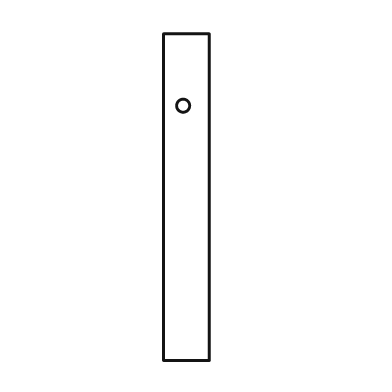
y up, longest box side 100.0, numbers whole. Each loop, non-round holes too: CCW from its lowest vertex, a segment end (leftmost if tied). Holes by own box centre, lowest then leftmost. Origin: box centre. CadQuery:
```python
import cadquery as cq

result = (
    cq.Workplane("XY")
    .moveTo(-7.0, -50.0)
    .lineTo(7.0, -50.0)
    .lineTo(7.0, 50.0)
    .lineTo(-7.0, 50.0)
    .close()
    .moveTo(-1.0, 28.0)
    .circle(2.0)
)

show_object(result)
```